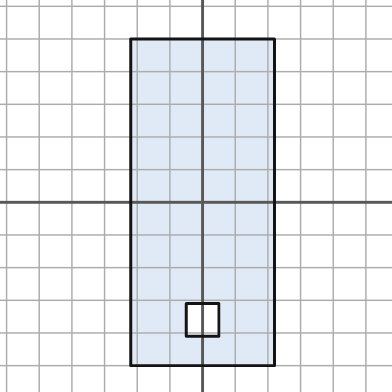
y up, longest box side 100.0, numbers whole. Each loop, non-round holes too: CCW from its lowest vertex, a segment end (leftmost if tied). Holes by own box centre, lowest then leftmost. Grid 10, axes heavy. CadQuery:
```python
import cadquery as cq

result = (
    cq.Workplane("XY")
    .moveTo(-22.0, -50.0)
    .lineTo(22.0, -50.0)
    .lineTo(22.0, 50.0)
    .lineTo(-22.0, 50.0)
    .close()
    .moveTo(-5.0, -41.0)
    .lineTo(5.0, -41.0)
    .lineTo(5.0, -31.0)
    .lineTo(-5.0, -31.0)
    .close()
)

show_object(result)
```